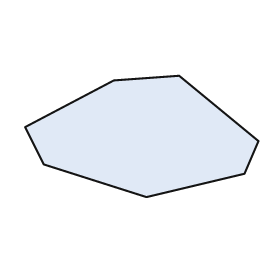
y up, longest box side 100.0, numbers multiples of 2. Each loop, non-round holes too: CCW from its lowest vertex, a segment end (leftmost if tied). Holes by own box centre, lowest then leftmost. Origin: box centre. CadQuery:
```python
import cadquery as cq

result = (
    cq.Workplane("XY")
    .moveTo(2.0, -26.0)
    .lineTo(44.0, -16.0)
    .lineTo(50.0, -2.0)
    .lineTo(16.0, 26.0)
    .lineTo(-12.0, 24.0)
    .lineTo(-50.0, 4.0)
    .lineTo(-42.0, -12.0)
    .close()
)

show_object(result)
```